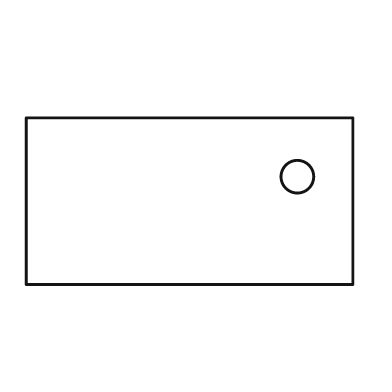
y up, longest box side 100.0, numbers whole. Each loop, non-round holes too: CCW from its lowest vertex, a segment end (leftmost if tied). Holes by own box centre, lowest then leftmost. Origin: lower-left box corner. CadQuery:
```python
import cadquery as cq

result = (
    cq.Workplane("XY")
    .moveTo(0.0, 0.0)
    .lineTo(100.0, 0.0)
    .lineTo(100.0, 51.0)
    .lineTo(0.0, 51.0)
    .close()
    .moveTo(83.0, 33.0)
    .circle(5.0)
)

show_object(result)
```